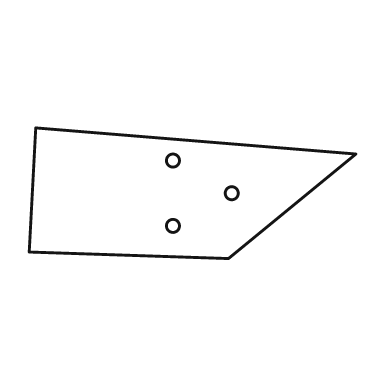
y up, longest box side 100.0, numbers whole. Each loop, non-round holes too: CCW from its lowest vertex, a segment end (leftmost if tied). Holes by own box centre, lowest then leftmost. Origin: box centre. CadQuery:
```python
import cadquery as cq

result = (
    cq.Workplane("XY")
    .moveTo(11.0, -20.0)
    .lineTo(50.0, 12.0)
    .lineTo(-48.0, 20.0)
    .lineTo(-50.0, -18.0)
    .close()
    .moveTo(-6.0, -10.0)
    .circle(2.0)
    .moveTo(12.0, 0.0)
    .circle(2.0)
    .moveTo(-6.0, 10.0)
    .circle(2.0)
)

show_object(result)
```